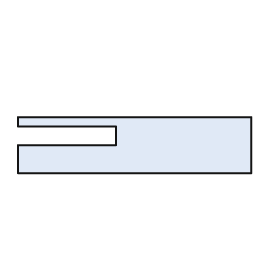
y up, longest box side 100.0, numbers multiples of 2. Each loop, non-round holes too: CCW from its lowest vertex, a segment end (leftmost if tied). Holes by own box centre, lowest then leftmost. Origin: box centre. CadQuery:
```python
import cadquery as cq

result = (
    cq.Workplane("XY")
    .moveTo(-50.0, -12.0)
    .lineTo(50.0, -12.0)
    .lineTo(50.0, 12.0)
    .lineTo(-50.0, 12.0)
    .lineTo(-50.0, 8.0)
    .lineTo(-8.0, 8.0)
    .lineTo(-8.0, 0.0)
    .lineTo(-50.0, 0.0)
    .close()
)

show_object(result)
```